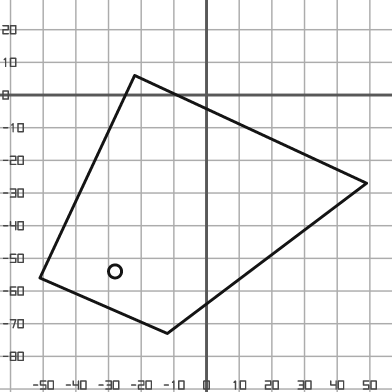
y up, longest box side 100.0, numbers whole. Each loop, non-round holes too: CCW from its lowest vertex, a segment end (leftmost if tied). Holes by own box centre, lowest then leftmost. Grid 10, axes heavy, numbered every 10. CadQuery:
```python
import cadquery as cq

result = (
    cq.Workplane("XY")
    .moveTo(-12.0, -73.0)
    .lineTo(49.0, -27.0)
    .lineTo(-22.0, 6.0)
    .lineTo(-51.0, -56.0)
    .close()
    .moveTo(-28.0, -54.0)
    .circle(2.0)
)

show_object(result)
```